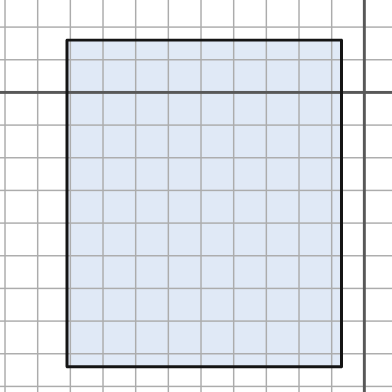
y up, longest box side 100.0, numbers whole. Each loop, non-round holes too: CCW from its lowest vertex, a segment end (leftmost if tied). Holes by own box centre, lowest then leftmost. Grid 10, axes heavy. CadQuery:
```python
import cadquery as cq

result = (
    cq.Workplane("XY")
    .moveTo(-91.0, -84.0)
    .lineTo(-7.0, -84.0)
    .lineTo(-7.0, 16.0)
    .lineTo(-91.0, 16.0)
    .close()
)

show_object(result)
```